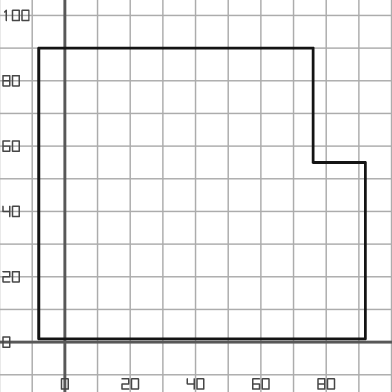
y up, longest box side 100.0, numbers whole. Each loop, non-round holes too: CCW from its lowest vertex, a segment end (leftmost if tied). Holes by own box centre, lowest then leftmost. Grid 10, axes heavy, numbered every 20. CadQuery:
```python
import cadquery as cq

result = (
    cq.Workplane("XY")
    .moveTo(-8.0, 1.0)
    .lineTo(92.0, 1.0)
    .lineTo(92.0, 55.0)
    .lineTo(76.0, 55.0)
    .lineTo(76.0, 90.0)
    .lineTo(-8.0, 90.0)
    .close()
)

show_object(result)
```